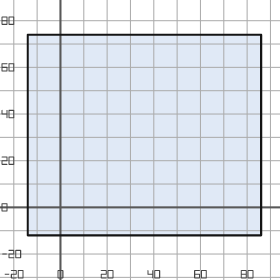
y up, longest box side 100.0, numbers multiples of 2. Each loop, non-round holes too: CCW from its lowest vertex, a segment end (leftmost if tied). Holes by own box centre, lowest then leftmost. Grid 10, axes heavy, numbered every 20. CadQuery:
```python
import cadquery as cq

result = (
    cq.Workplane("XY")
    .moveTo(-14.0, -12.0)
    .lineTo(86.0, -12.0)
    .lineTo(86.0, 74.0)
    .lineTo(-14.0, 74.0)
    .close()
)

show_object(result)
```